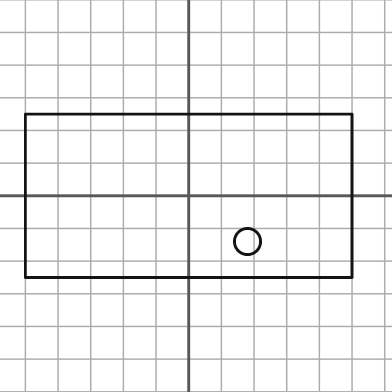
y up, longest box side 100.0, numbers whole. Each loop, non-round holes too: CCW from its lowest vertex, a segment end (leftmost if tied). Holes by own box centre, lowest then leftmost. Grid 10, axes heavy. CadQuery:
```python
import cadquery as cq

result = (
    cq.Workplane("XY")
    .moveTo(-50.0, -25.0)
    .lineTo(50.0, -25.0)
    .lineTo(50.0, 25.0)
    .lineTo(-50.0, 25.0)
    .close()
    .moveTo(18.0, -14.0)
    .circle(4.0)
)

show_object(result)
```